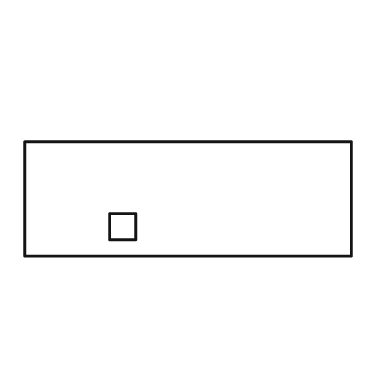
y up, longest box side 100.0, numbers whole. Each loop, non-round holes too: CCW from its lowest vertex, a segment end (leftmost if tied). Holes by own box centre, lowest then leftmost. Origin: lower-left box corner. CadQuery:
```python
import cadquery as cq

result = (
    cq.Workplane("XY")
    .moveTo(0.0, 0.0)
    .lineTo(100.0, 0.0)
    .lineTo(100.0, 35.0)
    .lineTo(0.0, 35.0)
    .close()
    .moveTo(26.0, 5.0)
    .lineTo(34.0, 5.0)
    .lineTo(34.0, 13.0)
    .lineTo(26.0, 13.0)
    .close()
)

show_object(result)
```